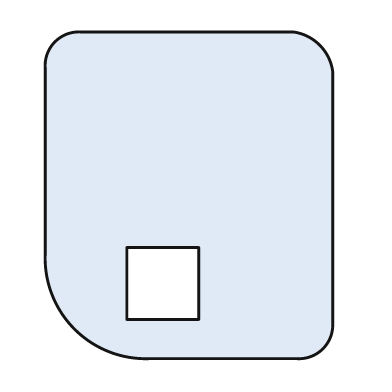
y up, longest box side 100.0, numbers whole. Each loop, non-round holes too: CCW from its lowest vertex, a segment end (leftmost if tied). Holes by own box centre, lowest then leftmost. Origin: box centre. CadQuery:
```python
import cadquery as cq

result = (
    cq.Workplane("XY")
    .moveTo(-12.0, -50.0)
    .lineTo(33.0, -50.0)
    .threePointArc((41.0, -47.0), (44.0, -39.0))
    .lineTo(44.0, 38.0)
    .threePointArc((40.0, 46.0), (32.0, 50.0))
    .lineTo(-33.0, 50.0)
    .threePointArc((-41.0, 47.0), (-44.0, 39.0))
    .lineTo(-44.0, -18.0)
    .threePointArc((-35.0, -41.0), (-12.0, -50.0))
    .close()
    .moveTo(-19.0, -38.0)
    .lineTo(3.0, -38.0)
    .lineTo(3.0, -16.0)
    .lineTo(-19.0, -16.0)
    .close()
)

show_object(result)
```